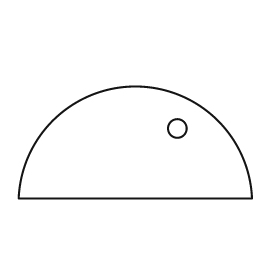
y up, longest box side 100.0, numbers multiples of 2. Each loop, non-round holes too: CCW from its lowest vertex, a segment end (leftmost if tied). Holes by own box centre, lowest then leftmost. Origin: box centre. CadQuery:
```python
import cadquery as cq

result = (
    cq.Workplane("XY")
    .moveTo(-50.0, -24.0)
    .lineTo(50.0, -24.0)
    .threePointArc((0.0, 24.0), (-50.0, -24.0))
    .close()
    .moveTo(18.0, 6.0)
    .circle(4.0)
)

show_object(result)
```